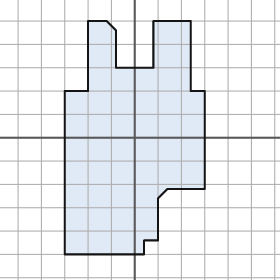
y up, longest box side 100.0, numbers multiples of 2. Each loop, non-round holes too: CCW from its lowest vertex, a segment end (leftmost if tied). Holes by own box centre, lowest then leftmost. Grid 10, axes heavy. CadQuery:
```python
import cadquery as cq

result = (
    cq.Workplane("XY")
    .moveTo(-30.0, -50.0)
    .lineTo(4.0, -50.0)
    .lineTo(4.0, -44.0)
    .lineTo(10.0, -44.0)
    .lineTo(10.0, -26.0)
    .lineTo(14.0, -22.0)
    .lineTo(30.0, -22.0)
    .lineTo(30.0, 20.0)
    .lineTo(24.0, 20.0)
    .lineTo(24.0, 50.0)
    .lineTo(8.0, 50.0)
    .lineTo(8.0, 30.0)
    .lineTo(-8.0, 30.0)
    .lineTo(-8.0, 46.0)
    .lineTo(-12.0, 50.0)
    .lineTo(-20.0, 50.0)
    .lineTo(-20.0, 20.0)
    .lineTo(-30.0, 20.0)
    .close()
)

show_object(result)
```